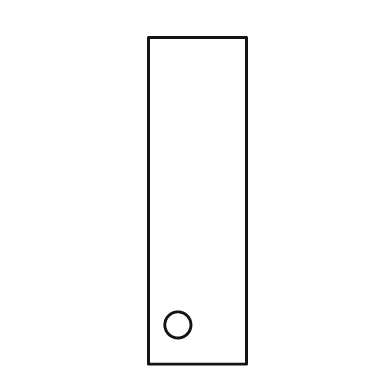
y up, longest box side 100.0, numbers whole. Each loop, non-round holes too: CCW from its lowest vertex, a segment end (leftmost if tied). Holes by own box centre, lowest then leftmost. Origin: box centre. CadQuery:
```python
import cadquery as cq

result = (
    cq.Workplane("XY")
    .moveTo(-15.0, -50.0)
    .lineTo(15.0, -50.0)
    .lineTo(15.0, 50.0)
    .lineTo(-15.0, 50.0)
    .close()
    .moveTo(-6.0, -38.0)
    .circle(4.0)
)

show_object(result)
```